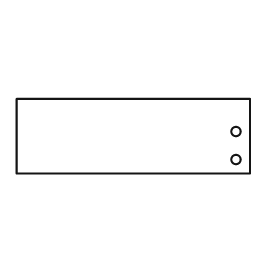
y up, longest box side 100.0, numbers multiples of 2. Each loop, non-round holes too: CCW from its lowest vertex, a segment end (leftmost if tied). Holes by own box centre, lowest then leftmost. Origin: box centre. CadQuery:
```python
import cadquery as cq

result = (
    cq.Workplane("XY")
    .moveTo(-50.0, -16.0)
    .lineTo(50.0, -16.0)
    .lineTo(50.0, 16.0)
    .lineTo(-50.0, 16.0)
    .close()
    .moveTo(44.0, -10.0)
    .circle(2.0)
    .moveTo(44.0, 2.0)
    .circle(2.0)
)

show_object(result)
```